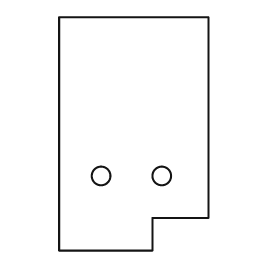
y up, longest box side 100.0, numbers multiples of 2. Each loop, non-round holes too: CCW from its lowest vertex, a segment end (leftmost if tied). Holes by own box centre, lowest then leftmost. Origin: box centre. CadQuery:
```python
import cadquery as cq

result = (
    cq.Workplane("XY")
    .moveTo(-32.0, -50.0)
    .lineTo(8.0, -50.0)
    .lineTo(8.0, -36.0)
    .lineTo(32.0, -36.0)
    .lineTo(32.0, 50.0)
    .lineTo(-32.0, 50.0)
    .close()
    .moveTo(-14.0, -18.0)
    .circle(4.0)
    .moveTo(12.0, -18.0)
    .circle(4.0)
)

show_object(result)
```